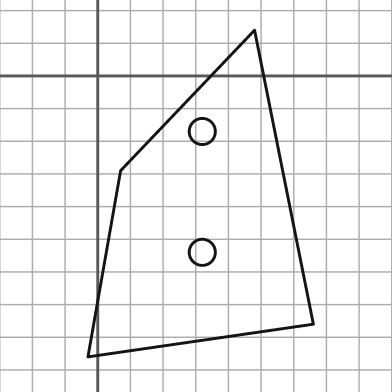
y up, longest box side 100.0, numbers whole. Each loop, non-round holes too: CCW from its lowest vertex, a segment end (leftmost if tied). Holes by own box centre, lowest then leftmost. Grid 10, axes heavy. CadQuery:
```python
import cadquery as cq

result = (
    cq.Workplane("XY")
    .moveTo(-3.0, -86.0)
    .lineTo(66.0, -76.0)
    .lineTo(48.0, 14.0)
    .lineTo(7.0, -29.0)
    .close()
    .moveTo(32.0, -54.0)
    .circle(4.0)
    .moveTo(32.0, -17.0)
    .circle(4.0)
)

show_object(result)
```